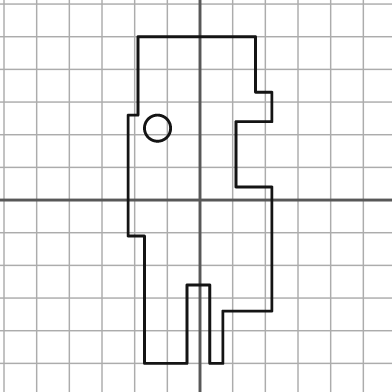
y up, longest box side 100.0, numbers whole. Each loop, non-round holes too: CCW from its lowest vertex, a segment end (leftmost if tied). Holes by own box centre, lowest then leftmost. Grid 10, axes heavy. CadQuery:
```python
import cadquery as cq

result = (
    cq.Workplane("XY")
    .moveTo(-17.0, -50.0)
    .lineTo(-4.0, -50.0)
    .lineTo(-4.0, -26.0)
    .lineTo(3.0, -26.0)
    .lineTo(3.0, -50.0)
    .lineTo(7.0, -50.0)
    .lineTo(7.0, -34.0)
    .lineTo(22.0, -34.0)
    .lineTo(22.0, 4.0)
    .lineTo(11.0, 4.0)
    .lineTo(11.0, 24.0)
    .lineTo(22.0, 24.0)
    .lineTo(22.0, 33.0)
    .lineTo(17.0, 33.0)
    .lineTo(17.0, 50.0)
    .lineTo(-19.0, 50.0)
    .lineTo(-19.0, 26.0)
    .lineTo(-22.0, 26.0)
    .lineTo(-22.0, -11.0)
    .lineTo(-17.0, -11.0)
    .close()
    .moveTo(-13.0, 22.0)
    .circle(4.0)
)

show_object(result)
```